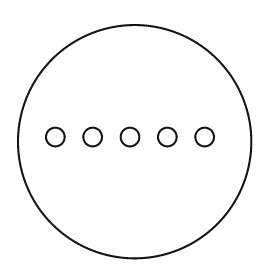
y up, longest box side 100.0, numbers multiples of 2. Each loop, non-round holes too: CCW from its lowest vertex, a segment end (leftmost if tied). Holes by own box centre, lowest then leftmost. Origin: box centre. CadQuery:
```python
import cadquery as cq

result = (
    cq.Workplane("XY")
    .moveTo(0.0, 0.0)
    .circle(50.0)
    .moveTo(-34.0, 2.0)
    .circle(4.0)
    .moveTo(-18.0, 2.0)
    .circle(4.0)
    .moveTo(-2.0, 2.0)
    .circle(4.0)
    .moveTo(14.0, 2.0)
    .circle(4.0)
    .moveTo(30.0, 2.0)
    .circle(4.0)
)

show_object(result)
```